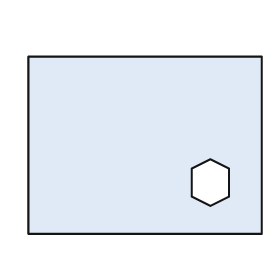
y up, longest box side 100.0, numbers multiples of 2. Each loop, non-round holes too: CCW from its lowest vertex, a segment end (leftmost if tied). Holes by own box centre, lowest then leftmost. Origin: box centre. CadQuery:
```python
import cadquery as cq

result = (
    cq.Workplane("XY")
    .moveTo(-50.0, -38.0)
    .lineTo(50.0, -38.0)
    .lineTo(50.0, 38.0)
    .lineTo(-50.0, 38.0)
    .close()
    .moveTo(28.0, -26.0)
    .lineTo(36.0, -22.0)
    .lineTo(36.0, -10.0)
    .lineTo(28.0, -6.0)
    .lineTo(20.0, -10.0)
    .lineTo(20.0, -22.0)
    .close()
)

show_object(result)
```